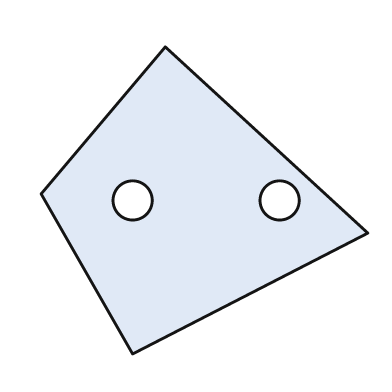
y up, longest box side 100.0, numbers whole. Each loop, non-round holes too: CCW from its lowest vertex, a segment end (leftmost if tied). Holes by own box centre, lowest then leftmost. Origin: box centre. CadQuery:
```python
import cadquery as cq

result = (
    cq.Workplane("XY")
    .moveTo(-22.0, -47.0)
    .lineTo(50.0, -10.0)
    .lineTo(-12.0, 47.0)
    .lineTo(-50.0, 2.0)
    .close()
    .moveTo(-22.0, 0.0)
    .circle(6.0)
    .moveTo(23.0, 0.0)
    .circle(6.0)
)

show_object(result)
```